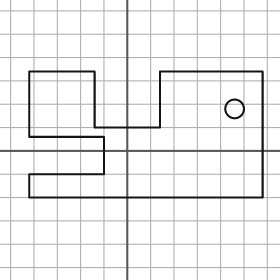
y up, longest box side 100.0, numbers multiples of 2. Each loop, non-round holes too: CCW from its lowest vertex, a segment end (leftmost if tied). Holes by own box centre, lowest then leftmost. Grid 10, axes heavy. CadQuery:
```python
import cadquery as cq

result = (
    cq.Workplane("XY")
    .moveTo(-42.0, -20.0)
    .lineTo(58.0, -20.0)
    .lineTo(58.0, 34.0)
    .lineTo(14.0, 34.0)
    .lineTo(14.0, 10.0)
    .lineTo(-14.0, 10.0)
    .lineTo(-14.0, 34.0)
    .lineTo(-42.0, 34.0)
    .lineTo(-42.0, 6.0)
    .lineTo(-10.0, 6.0)
    .lineTo(-10.0, -10.0)
    .lineTo(-42.0, -10.0)
    .close()
    .moveTo(46.0, 18.0)
    .circle(4.0)
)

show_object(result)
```